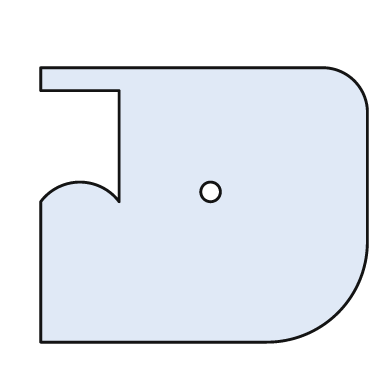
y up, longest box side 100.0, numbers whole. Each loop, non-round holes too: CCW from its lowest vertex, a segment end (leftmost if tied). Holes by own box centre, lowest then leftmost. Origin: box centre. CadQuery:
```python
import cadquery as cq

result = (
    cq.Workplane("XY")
    .moveTo(-50.0, -42.0)
    .lineTo(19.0, -42.0)
    .threePointArc((41.0, -33.0), (50.0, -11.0))
    .lineTo(50.0, 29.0)
    .threePointArc((46.0, 38.0), (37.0, 42.0))
    .lineTo(-50.0, 42.0)
    .lineTo(-50.0, 35.0)
    .lineTo(-26.0, 35.0)
    .lineTo(-26.0, 1.0)
    .threePointArc((-38.0, 7.0), (-50.0, 1.0))
    .close()
    .moveTo(2.0, 4.0)
    .circle(3.0)
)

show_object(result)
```